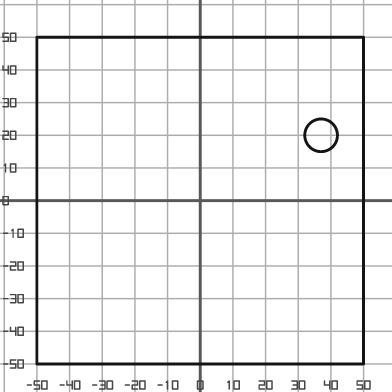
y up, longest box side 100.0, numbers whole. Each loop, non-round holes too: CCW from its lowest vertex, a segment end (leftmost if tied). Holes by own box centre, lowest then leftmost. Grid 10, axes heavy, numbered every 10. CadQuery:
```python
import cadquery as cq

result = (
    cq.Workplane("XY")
    .moveTo(-50.0, -50.0)
    .lineTo(50.0, -50.0)
    .lineTo(50.0, 50.0)
    .lineTo(-50.0, 50.0)
    .close()
    .moveTo(37.0, 20.0)
    .circle(5.0)
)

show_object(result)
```